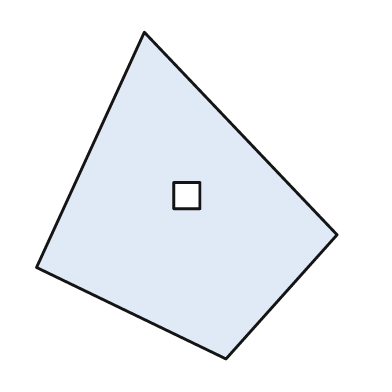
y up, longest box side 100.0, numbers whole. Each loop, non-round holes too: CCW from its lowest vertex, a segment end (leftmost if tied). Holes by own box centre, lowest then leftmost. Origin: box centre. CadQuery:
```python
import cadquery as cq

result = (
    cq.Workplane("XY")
    .moveTo(12.0, -50.0)
    .lineTo(46.0, -12.0)
    .lineTo(-13.0, 50.0)
    .lineTo(-46.0, -22.0)
    .close()
    .moveTo(-4.0, -4.0)
    .lineTo(4.0, -4.0)
    .lineTo(4.0, 4.0)
    .lineTo(-4.0, 4.0)
    .close()
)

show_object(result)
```